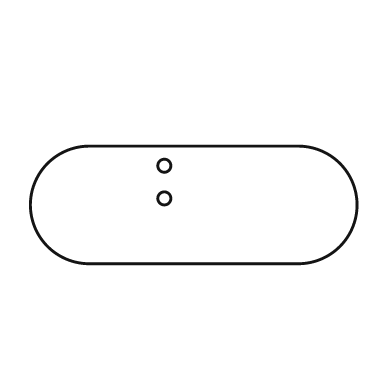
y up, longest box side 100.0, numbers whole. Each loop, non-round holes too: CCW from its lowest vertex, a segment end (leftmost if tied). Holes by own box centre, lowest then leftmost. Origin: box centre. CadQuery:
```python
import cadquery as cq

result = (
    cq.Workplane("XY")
    .moveTo(-32.0, -18.0)
    .lineTo(32.0, -18.0)
    .threePointArc((50.0, 0.0), (32.0, 18.0))
    .lineTo(-32.0, 18.0)
    .threePointArc((-50.0, 0.0), (-32.0, -18.0))
    .close()
    .moveTo(-9.0, 2.0)
    .circle(2.0)
    .moveTo(-9.0, 12.0)
    .circle(2.0)
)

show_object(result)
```